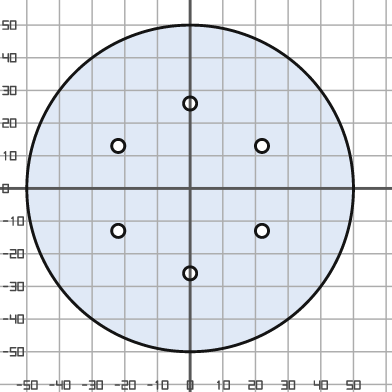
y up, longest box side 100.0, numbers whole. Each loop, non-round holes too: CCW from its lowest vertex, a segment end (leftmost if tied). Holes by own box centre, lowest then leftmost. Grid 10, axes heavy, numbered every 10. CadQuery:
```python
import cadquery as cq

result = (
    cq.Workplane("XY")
    .moveTo(0.0, 0.0)
    .circle(50.0)
    .moveTo(0.0, -26.0)
    .circle(2.0)
    .moveTo(-22.0, -13.0)
    .circle(2.0)
    .moveTo(22.0, -13.0)
    .circle(2.0)
    .moveTo(-22.0, 13.0)
    .circle(2.0)
    .moveTo(22.0, 13.0)
    .circle(2.0)
    .moveTo(0.0, 26.0)
    .circle(2.0)
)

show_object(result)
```